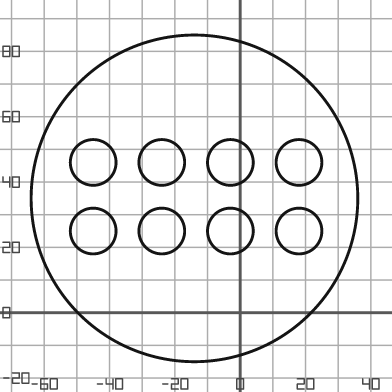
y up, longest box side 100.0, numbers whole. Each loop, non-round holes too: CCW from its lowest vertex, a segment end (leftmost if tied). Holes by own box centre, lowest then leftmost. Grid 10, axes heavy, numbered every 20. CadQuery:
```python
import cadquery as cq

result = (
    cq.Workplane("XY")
    .moveTo(-14.0, 35.0)
    .circle(50.0)
    .moveTo(-45.0, 25.0)
    .circle(7.0)
    .moveTo(-24.0, 25.0)
    .circle(7.0)
    .moveTo(-3.0, 25.0)
    .circle(7.0)
    .moveTo(18.0, 25.0)
    .circle(7.0)
    .moveTo(-45.0, 46.0)
    .circle(7.0)
    .moveTo(-24.0, 46.0)
    .circle(7.0)
    .moveTo(-3.0, 46.0)
    .circle(7.0)
    .moveTo(18.0, 46.0)
    .circle(7.0)
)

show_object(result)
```